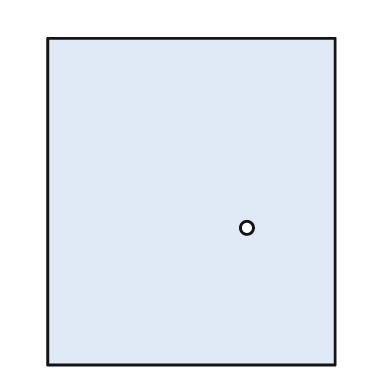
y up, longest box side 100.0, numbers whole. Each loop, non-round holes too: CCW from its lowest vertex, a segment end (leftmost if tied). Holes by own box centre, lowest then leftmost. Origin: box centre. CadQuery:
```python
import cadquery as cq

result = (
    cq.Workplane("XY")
    .moveTo(-44.0, -50.0)
    .lineTo(44.0, -50.0)
    .lineTo(44.0, 50.0)
    .lineTo(-44.0, 50.0)
    .close()
    .moveTo(17.0, -8.0)
    .circle(2.0)
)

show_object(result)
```